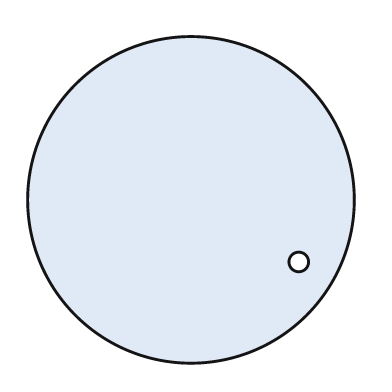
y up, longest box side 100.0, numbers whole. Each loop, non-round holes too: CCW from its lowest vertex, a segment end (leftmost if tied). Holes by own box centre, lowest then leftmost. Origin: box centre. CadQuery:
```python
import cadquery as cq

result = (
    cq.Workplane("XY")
    .moveTo(0.0, 0.0)
    .circle(50.0)
    .moveTo(33.0, -19.0)
    .circle(3.0)
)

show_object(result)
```